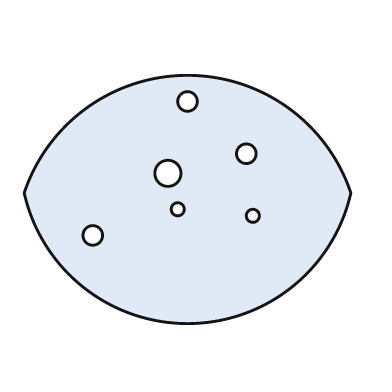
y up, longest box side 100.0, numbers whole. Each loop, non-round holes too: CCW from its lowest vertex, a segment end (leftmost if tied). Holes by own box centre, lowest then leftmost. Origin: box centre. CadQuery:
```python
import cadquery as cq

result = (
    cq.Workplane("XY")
    .moveTo(-50.0, 2.0)
    .threePointArc((0.0, -38.0), (50.0, 2.0))
    .threePointArc((0.0, 38.0), (-50.0, 2.0))
    .close()
    .moveTo(-29.0, -11.0)
    .circle(3.0)
    .moveTo(20.0, -5.0)
    .circle(2.0)
    .moveTo(-3.0, -3.0)
    .circle(2.0)
    .moveTo(-6.0, 8.0)
    .circle(4.0)
    .moveTo(18.0, 14.0)
    .circle(3.0)
    .moveTo(0.0, 30.0)
    .circle(3.0)
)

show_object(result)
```